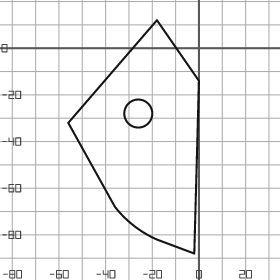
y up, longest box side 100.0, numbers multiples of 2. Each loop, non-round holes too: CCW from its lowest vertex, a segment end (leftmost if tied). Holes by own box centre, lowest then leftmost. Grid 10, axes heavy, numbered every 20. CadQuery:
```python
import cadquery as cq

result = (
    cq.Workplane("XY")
    .moveTo(-2.0, -88.0)
    .lineTo(0.0, -14.0)
    .lineTo(-18.0, 12.0)
    .lineTo(-56.0, -32.0)
    .lineTo(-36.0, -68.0)
    .threePointArc((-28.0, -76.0), (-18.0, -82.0))
    .close()
    .moveTo(-26.0, -28.0)
    .circle(6.0)
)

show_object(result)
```